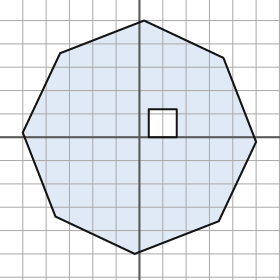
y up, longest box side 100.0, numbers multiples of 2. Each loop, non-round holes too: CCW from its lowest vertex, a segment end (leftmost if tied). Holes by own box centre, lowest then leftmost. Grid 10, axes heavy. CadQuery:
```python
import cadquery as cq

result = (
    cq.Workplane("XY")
    .moveTo(-2.0, -50.0)
    .lineTo(34.0, -36.0)
    .lineTo(50.0, -2.0)
    .lineTo(36.0, 34.0)
    .lineTo(2.0, 50.0)
    .lineTo(-34.0, 36.0)
    .lineTo(-50.0, 2.0)
    .lineTo(-36.0, -34.0)
    .close()
    .moveTo(4.0, 0.0)
    .lineTo(16.0, 0.0)
    .lineTo(16.0, 12.0)
    .lineTo(4.0, 12.0)
    .close()
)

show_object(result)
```